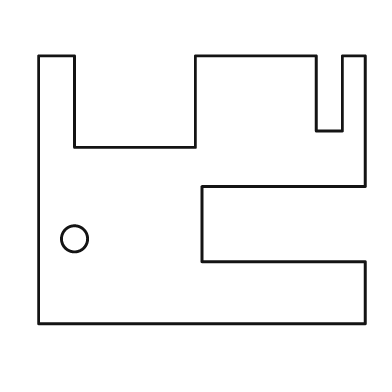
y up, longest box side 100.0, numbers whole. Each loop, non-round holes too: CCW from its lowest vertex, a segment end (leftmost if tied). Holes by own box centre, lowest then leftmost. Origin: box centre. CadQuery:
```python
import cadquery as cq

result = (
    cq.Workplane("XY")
    .moveTo(-50.0, -41.0)
    .lineTo(50.0, -41.0)
    .lineTo(50.0, -22.0)
    .lineTo(0.0, -22.0)
    .lineTo(0.0, 1.0)
    .lineTo(50.0, 1.0)
    .lineTo(50.0, 41.0)
    .lineTo(43.0, 41.0)
    .lineTo(43.0, 18.0)
    .lineTo(35.0, 18.0)
    .lineTo(35.0, 41.0)
    .lineTo(-2.0, 41.0)
    .lineTo(-2.0, 13.0)
    .lineTo(-39.0, 13.0)
    .lineTo(-39.0, 41.0)
    .lineTo(-50.0, 41.0)
    .close()
    .moveTo(-39.0, -15.0)
    .circle(4.0)
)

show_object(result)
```